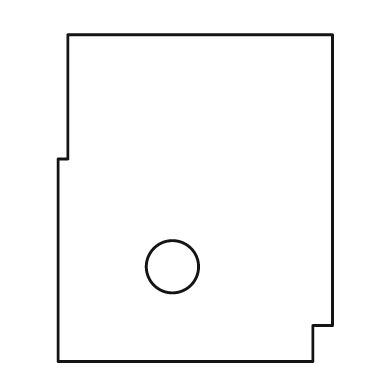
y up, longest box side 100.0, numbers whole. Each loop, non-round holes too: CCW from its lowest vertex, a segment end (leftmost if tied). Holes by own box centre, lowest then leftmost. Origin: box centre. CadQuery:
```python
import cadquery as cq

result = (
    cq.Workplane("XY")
    .moveTo(-42.0, -50.0)
    .lineTo(36.0, -50.0)
    .lineTo(36.0, -39.0)
    .lineTo(42.0, -39.0)
    .lineTo(42.0, 50.0)
    .lineTo(-39.0, 50.0)
    .lineTo(-39.0, 12.0)
    .lineTo(-42.0, 12.0)
    .close()
    .moveTo(-7.0, -21.0)
    .circle(8.0)
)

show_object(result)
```